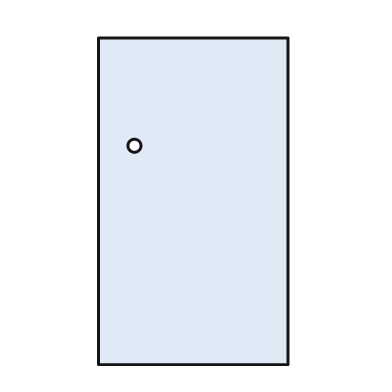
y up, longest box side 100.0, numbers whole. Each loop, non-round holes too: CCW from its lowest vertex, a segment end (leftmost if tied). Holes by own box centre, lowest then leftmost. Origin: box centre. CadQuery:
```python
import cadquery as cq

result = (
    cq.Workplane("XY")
    .moveTo(-29.0, -50.0)
    .lineTo(29.0, -50.0)
    .lineTo(29.0, 50.0)
    .lineTo(-29.0, 50.0)
    .close()
    .moveTo(-18.0, 17.0)
    .circle(2.0)
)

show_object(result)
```